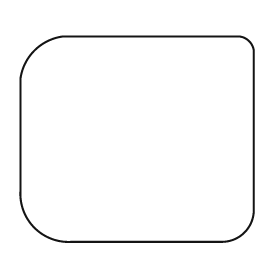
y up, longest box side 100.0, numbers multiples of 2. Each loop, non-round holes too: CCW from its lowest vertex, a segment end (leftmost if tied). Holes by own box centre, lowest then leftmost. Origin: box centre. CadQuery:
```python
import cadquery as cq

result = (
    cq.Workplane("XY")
    .moveTo(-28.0, -44.0)
    .lineTo(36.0, -44.0)
    .threePointArc((46.0, -40.0), (50.0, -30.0))
    .lineTo(50.0, 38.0)
    .threePointArc((48.0, 42.0), (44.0, 44.0))
    .lineTo(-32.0, 44.0)
    .threePointArc((-44.0, 38.0), (-50.0, 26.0))
    .lineTo(-50.0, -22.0)
    .threePointArc((-44.0, -38.0), (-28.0, -44.0))
    .close()
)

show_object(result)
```